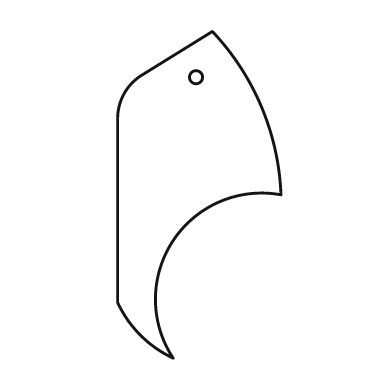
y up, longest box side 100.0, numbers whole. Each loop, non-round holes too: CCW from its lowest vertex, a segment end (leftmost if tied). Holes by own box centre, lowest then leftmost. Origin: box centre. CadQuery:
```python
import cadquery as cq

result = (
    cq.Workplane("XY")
    .moveTo(-8.0, -50.0)
    .threePointArc((-8.0, -14.0), (25.0, 0.0))
    .threePointArc((19.0, 27.0), (4.0, 50.0))
    .lineTo(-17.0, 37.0)
    .threePointArc((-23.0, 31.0), (-25.0, 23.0))
    .lineTo(-25.0, -33.0)
    .threePointArc((-18.0, -43.0), (-8.0, -50.0))
    .close()
    .moveTo(-1.0, 36.0)
    .circle(2.0)
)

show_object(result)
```